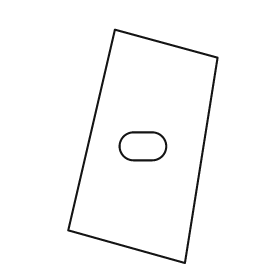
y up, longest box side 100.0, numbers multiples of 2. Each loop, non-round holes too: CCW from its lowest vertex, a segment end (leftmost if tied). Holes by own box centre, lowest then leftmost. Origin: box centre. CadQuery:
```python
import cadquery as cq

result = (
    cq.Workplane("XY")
    .moveTo(18.0, -50.0)
    .lineTo(32.0, 38.0)
    .lineTo(-12.0, 50.0)
    .lineTo(-32.0, -36.0)
    .close()
    .moveTo(-4.0, -6.0)
    .lineTo(4.0, -6.0)
    .threePointArc((10.0, 0.0), (4.0, 6.0))
    .lineTo(-4.0, 6.0)
    .threePointArc((-10.0, 0.0), (-4.0, -6.0))
    .close()
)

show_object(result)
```